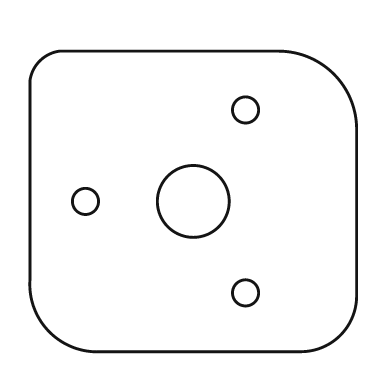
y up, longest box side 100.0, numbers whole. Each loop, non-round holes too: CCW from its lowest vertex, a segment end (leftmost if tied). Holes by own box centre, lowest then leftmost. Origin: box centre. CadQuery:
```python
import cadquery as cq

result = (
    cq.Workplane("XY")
    .moveTo(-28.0, -46.0)
    .lineTo(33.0, -46.0)
    .threePointArc((45.0, -41.0), (50.0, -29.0))
    .lineTo(50.0, 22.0)
    .threePointArc((43.0, 39.0), (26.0, 46.0))
    .lineTo(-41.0, 46.0)
    .threePointArc((-47.0, 43.0), (-50.0, 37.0))
    .lineTo(-50.0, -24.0)
    .threePointArc((-44.0, -40.0), (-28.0, -46.0))
    .close()
    .moveTo(16.0, -28.0)
    .circle(4.0)
    .moveTo(-33.0, 0.0)
    .circle(4.0)
    .moveTo(0.0, 0.0)
    .circle(11.0)
    .moveTo(16.0, 28.0)
    .circle(4.0)
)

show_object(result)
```